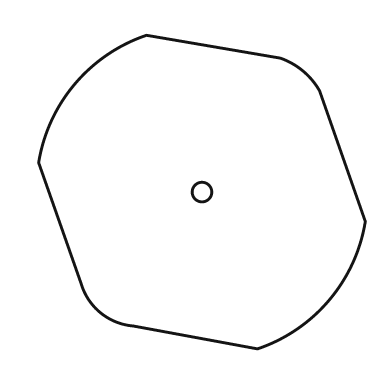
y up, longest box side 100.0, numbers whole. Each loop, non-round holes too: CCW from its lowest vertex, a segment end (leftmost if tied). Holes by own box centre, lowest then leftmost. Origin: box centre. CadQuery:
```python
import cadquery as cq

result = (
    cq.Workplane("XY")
    .moveTo(17.0, -48.0)
    .threePointArc((39.0, -33.0), (50.0, -9.0))
    .lineTo(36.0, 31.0)
    .threePointArc((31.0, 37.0), (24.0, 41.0))
    .lineTo(-17.0, 48.0)
    .threePointArc((-39.0, 33.0), (-50.0, 9.0))
    .lineTo(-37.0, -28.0)
    .threePointArc((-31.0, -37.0), (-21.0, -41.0))
    .close()
    .moveTo(0.0, 0.0)
    .circle(3.0)
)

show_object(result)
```